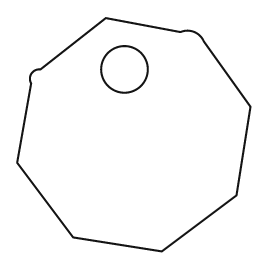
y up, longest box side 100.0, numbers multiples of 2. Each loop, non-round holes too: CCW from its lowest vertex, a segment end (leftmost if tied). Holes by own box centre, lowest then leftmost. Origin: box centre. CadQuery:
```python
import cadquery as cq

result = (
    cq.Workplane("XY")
    .moveTo(12.0, -50.0)
    .lineTo(44.0, -26.0)
    .lineTo(50.0, 12.0)
    .lineTo(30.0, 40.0)
    .threePointArc((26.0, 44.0), (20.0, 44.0))
    .lineTo(-12.0, 50.0)
    .lineTo(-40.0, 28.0)
    .threePointArc((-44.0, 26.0), (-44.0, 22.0))
    .lineTo(-50.0, -12.0)
    .lineTo(-26.0, -44.0)
    .close()
    .moveTo(-4.0, 28.0)
    .circle(10.0)
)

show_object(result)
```